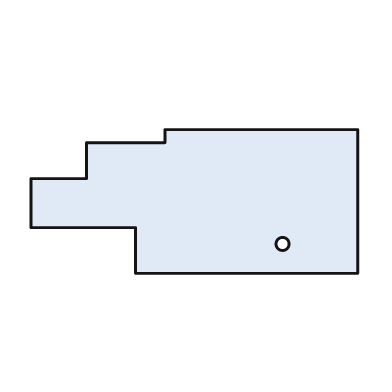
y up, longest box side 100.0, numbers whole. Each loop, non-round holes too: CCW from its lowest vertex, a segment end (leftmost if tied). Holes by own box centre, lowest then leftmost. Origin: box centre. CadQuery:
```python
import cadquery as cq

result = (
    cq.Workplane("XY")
    .moveTo(-18.0, -22.0)
    .lineTo(50.0, -22.0)
    .lineTo(50.0, 22.0)
    .lineTo(-9.0, 22.0)
    .lineTo(-9.0, 18.0)
    .lineTo(-33.0, 18.0)
    .lineTo(-33.0, 7.0)
    .lineTo(-50.0, 7.0)
    .lineTo(-50.0, -8.0)
    .lineTo(-18.0, -8.0)
    .close()
    .moveTo(27.0, -13.0)
    .circle(2.0)
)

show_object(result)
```